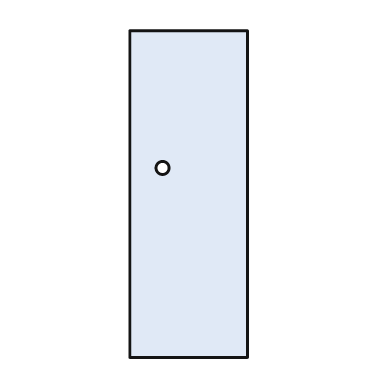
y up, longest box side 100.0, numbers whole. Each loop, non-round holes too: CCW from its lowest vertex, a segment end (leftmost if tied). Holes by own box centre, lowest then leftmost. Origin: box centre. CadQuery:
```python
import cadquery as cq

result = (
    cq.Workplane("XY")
    .moveTo(-18.0, -50.0)
    .lineTo(18.0, -50.0)
    .lineTo(18.0, 50.0)
    .lineTo(-18.0, 50.0)
    .close()
    .moveTo(-8.0, 8.0)
    .circle(2.0)
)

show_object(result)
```